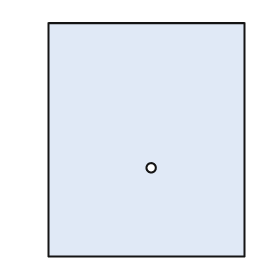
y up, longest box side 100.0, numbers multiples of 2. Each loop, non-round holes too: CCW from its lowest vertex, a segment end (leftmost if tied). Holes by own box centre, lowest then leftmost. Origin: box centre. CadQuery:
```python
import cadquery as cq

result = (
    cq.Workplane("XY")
    .moveTo(-42.0, -50.0)
    .lineTo(42.0, -50.0)
    .lineTo(42.0, 50.0)
    .lineTo(-42.0, 50.0)
    .close()
    .moveTo(2.0, -12.0)
    .circle(2.0)
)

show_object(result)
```